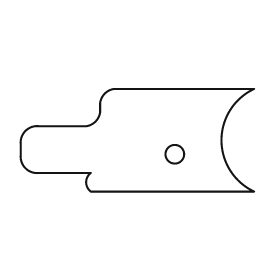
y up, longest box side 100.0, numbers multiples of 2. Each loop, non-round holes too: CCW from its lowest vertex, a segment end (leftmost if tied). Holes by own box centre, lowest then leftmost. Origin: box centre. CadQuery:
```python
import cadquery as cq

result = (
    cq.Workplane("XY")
    .moveTo(-20.0, -22.0)
    .lineTo(50.0, -22.0)
    .threePointArc((36.0, 0.0), (50.0, 22.0))
    .lineTo(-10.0, 22.0)
    .threePointArc((-14.0, 20.0), (-16.0, 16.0))
    .lineTo(-16.0, 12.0)
    .threePointArc((-18.0, 8.0), (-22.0, 6.0))
    .lineTo(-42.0, 6.0)
    .threePointArc((-48.0, 4.0), (-50.0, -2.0))
    .lineTo(-50.0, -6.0)
    .threePointArc((-48.0, -12.0), (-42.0, -14.0))
    .lineTo(-20.0, -14.0)
    .threePointArc((-22.0, -18.0), (-20.0, -22.0))
    .close()
    .moveTo(16.0, -6.0)
    .circle(4.0)
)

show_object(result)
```